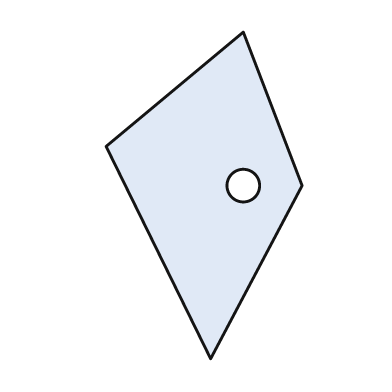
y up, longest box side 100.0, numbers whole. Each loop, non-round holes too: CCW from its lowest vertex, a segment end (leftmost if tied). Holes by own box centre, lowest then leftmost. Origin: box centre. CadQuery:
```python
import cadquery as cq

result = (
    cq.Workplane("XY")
    .moveTo(2.0, -50.0)
    .lineTo(30.0, 3.0)
    .lineTo(12.0, 50.0)
    .lineTo(-30.0, 15.0)
    .close()
    .moveTo(12.0, 3.0)
    .circle(5.0)
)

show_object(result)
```